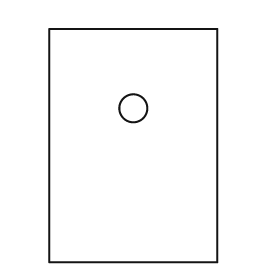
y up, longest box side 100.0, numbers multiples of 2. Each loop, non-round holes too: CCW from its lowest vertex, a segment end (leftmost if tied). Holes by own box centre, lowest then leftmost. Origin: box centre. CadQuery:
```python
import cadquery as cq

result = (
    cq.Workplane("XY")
    .moveTo(-36.0, -50.0)
    .lineTo(36.0, -50.0)
    .lineTo(36.0, 50.0)
    .lineTo(-36.0, 50.0)
    .close()
    .moveTo(0.0, 16.0)
    .circle(6.0)
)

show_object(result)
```